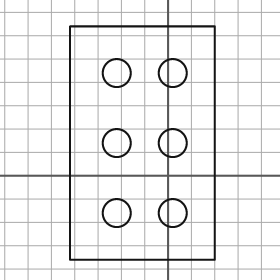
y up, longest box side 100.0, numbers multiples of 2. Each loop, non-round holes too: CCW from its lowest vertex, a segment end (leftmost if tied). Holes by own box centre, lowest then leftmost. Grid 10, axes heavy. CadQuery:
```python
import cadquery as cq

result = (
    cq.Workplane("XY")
    .moveTo(-42.0, -36.0)
    .lineTo(20.0, -36.0)
    .lineTo(20.0, 64.0)
    .lineTo(-42.0, 64.0)
    .close()
    .moveTo(-22.0, -16.0)
    .circle(6.0)
    .moveTo(2.0, -16.0)
    .circle(6.0)
    .moveTo(-22.0, 14.0)
    .circle(6.0)
    .moveTo(2.0, 14.0)
    .circle(6.0)
    .moveTo(-22.0, 44.0)
    .circle(6.0)
    .moveTo(2.0, 44.0)
    .circle(6.0)
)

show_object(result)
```